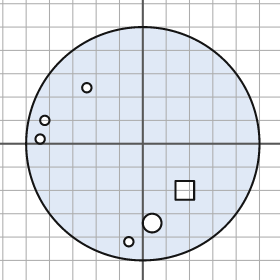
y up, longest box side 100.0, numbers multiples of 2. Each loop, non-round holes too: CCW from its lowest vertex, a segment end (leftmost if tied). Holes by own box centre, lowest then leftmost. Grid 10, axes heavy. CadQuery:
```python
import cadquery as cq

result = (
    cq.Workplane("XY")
    .moveTo(0.0, 0.0)
    .circle(50.0)
    .moveTo(-6.0, -42.0)
    .circle(2.0)
    .moveTo(4.0, -34.0)
    .circle(4.0)
    .moveTo(14.0, -24.0)
    .lineTo(22.0, -24.0)
    .lineTo(22.0, -16.0)
    .lineTo(14.0, -16.0)
    .close()
    .moveTo(-44.0, 2.0)
    .circle(2.0)
    .moveTo(-42.0, 10.0)
    .circle(2.0)
    .moveTo(-24.0, 24.0)
    .circle(2.0)
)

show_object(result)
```